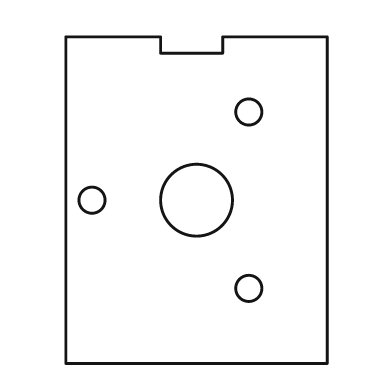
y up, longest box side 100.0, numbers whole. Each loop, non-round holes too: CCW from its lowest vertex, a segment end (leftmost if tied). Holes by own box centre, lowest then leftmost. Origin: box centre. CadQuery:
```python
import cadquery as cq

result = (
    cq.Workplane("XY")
    .moveTo(-40.0, -50.0)
    .lineTo(40.0, -50.0)
    .lineTo(40.0, 50.0)
    .lineTo(8.0, 50.0)
    .lineTo(8.0, 45.0)
    .lineTo(-11.0, 45.0)
    .lineTo(-11.0, 50.0)
    .lineTo(-40.0, 50.0)
    .close()
    .moveTo(16.0, -27.0)
    .circle(4.0)
    .moveTo(-32.0, 0.0)
    .circle(4.0)
    .moveTo(0.0, 0.0)
    .circle(11.0)
    .moveTo(16.0, 27.0)
    .circle(4.0)
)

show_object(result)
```